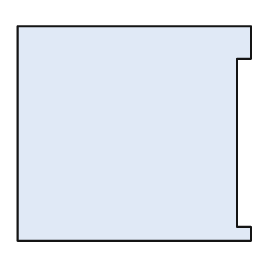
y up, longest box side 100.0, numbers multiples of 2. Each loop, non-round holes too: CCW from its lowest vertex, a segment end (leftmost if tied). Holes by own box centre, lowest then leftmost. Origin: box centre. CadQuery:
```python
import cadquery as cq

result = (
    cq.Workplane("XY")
    .moveTo(-50.0, -46.0)
    .lineTo(50.0, -46.0)
    .lineTo(50.0, -40.0)
    .lineTo(44.0, -40.0)
    .lineTo(44.0, 32.0)
    .lineTo(50.0, 32.0)
    .lineTo(50.0, 46.0)
    .lineTo(-50.0, 46.0)
    .close()
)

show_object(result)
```